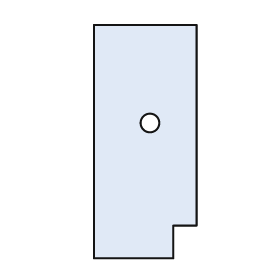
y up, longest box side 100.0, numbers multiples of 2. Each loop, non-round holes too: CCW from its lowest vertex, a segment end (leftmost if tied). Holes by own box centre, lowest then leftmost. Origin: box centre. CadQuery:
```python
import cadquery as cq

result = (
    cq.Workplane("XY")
    .moveTo(-22.0, -50.0)
    .lineTo(12.0, -50.0)
    .lineTo(12.0, -36.0)
    .lineTo(22.0, -36.0)
    .lineTo(22.0, 50.0)
    .lineTo(-22.0, 50.0)
    .close()
    .moveTo(2.0, 8.0)
    .circle(4.0)
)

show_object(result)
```